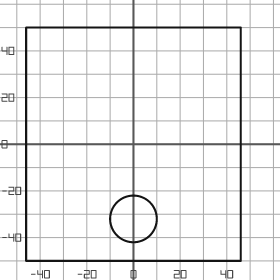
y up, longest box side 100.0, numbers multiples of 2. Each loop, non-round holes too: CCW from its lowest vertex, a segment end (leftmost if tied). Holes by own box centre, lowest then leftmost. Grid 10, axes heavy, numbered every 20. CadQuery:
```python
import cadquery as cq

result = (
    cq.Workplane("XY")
    .moveTo(-46.0, -50.0)
    .lineTo(46.0, -50.0)
    .lineTo(46.0, 50.0)
    .lineTo(-46.0, 50.0)
    .close()
    .moveTo(0.0, -32.0)
    .circle(10.0)
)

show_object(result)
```